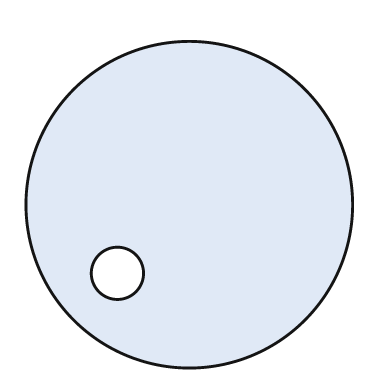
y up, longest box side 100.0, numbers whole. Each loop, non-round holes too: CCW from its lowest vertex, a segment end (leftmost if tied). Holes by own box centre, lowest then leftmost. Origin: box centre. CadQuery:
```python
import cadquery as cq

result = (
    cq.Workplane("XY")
    .moveTo(0.0, 0.0)
    .circle(50.0)
    .moveTo(-22.0, -21.0)
    .circle(8.0)
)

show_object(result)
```